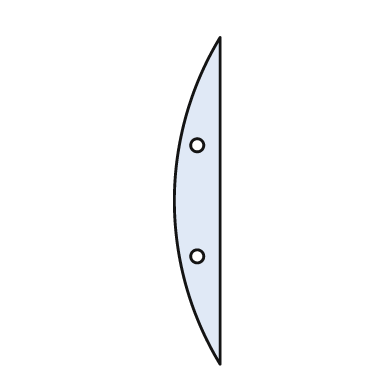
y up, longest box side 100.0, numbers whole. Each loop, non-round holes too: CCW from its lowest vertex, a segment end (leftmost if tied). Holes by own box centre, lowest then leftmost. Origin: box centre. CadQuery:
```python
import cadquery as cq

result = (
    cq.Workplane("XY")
    .moveTo(7.0, -50.0)
    .lineTo(7.0, 50.0)
    .threePointArc((-7.0, 0.0), (7.0, -50.0))
    .close()
    .moveTo(0.0, -17.0)
    .circle(2.0)
    .moveTo(0.0, 17.0)
    .circle(2.0)
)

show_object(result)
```